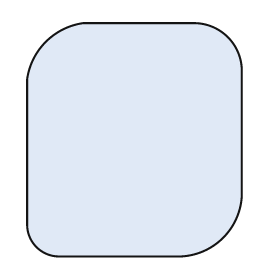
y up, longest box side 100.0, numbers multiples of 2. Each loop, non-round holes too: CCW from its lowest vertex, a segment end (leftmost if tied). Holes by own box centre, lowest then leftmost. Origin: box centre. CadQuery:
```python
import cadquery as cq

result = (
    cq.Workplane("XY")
    .moveTo(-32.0, -50.0)
    .lineTo(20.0, -50.0)
    .threePointArc((38.0, -42.0), (46.0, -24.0))
    .lineTo(46.0, 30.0)
    .threePointArc((40.0, 44.0), (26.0, 50.0))
    .lineTo(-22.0, 50.0)
    .threePointArc((-38.0, 42.0), (-46.0, 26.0))
    .lineTo(-46.0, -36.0)
    .threePointArc((-42.0, -46.0), (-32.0, -50.0))
    .close()
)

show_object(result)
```